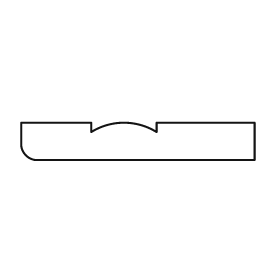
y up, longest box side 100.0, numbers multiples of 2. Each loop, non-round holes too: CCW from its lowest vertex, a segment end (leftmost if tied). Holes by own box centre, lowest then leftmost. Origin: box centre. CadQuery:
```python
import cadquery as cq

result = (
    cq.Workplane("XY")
    .moveTo(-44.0, -8.0)
    .lineTo(50.0, -8.0)
    .lineTo(50.0, 8.0)
    .lineTo(8.0, 8.0)
    .lineTo(8.0, 4.0)
    .threePointArc((-6.0, 8.0), (-20.0, 4.0))
    .lineTo(-20.0, 8.0)
    .lineTo(-50.0, 8.0)
    .lineTo(-50.0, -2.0)
    .threePointArc((-48.0, -6.0), (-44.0, -8.0))
    .close()
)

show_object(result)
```